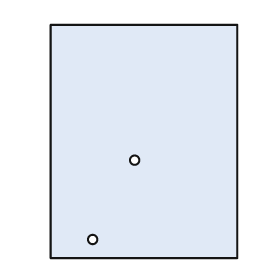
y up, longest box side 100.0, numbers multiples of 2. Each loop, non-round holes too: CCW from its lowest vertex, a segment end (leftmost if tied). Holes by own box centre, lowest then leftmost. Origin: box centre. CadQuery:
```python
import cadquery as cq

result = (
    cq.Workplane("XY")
    .moveTo(-40.0, -50.0)
    .lineTo(40.0, -50.0)
    .lineTo(40.0, 50.0)
    .lineTo(-40.0, 50.0)
    .close()
    .moveTo(-22.0, -42.0)
    .circle(2.0)
    .moveTo(-4.0, -8.0)
    .circle(2.0)
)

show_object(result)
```